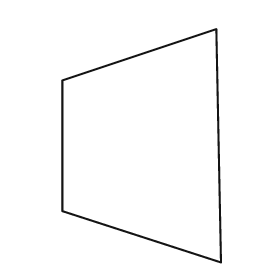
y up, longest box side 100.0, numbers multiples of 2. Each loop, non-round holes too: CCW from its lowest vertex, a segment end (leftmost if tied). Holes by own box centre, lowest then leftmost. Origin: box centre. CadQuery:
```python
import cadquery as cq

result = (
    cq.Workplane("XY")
    .moveTo(34.0, -50.0)
    .lineTo(32.0, 50.0)
    .lineTo(-34.0, 28.0)
    .lineTo(-34.0, -28.0)
    .close()
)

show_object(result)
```